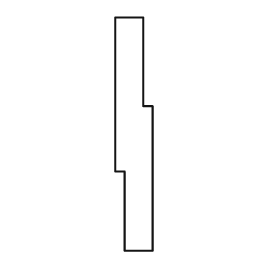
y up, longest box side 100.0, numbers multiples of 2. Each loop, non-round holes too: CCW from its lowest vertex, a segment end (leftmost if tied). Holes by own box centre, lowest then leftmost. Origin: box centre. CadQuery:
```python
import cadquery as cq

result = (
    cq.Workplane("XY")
    .moveTo(-4.0, -50.0)
    .lineTo(8.0, -50.0)
    .lineTo(8.0, 12.0)
    .lineTo(4.0, 12.0)
    .lineTo(4.0, 50.0)
    .lineTo(-8.0, 50.0)
    .lineTo(-8.0, -16.0)
    .lineTo(-4.0, -16.0)
    .close()
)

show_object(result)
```